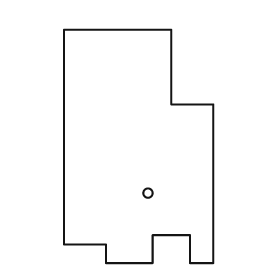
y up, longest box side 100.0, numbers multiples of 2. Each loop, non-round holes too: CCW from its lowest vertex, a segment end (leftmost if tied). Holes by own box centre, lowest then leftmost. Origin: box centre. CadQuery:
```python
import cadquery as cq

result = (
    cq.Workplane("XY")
    .moveTo(-14.0, -50.0)
    .lineTo(6.0, -50.0)
    .lineTo(6.0, -38.0)
    .lineTo(22.0, -38.0)
    .lineTo(22.0, -50.0)
    .lineTo(32.0, -50.0)
    .lineTo(32.0, 18.0)
    .lineTo(14.0, 18.0)
    .lineTo(14.0, 50.0)
    .lineTo(-32.0, 50.0)
    .lineTo(-32.0, -42.0)
    .lineTo(-14.0, -42.0)
    .close()
    .moveTo(4.0, -20.0)
    .circle(2.0)
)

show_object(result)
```